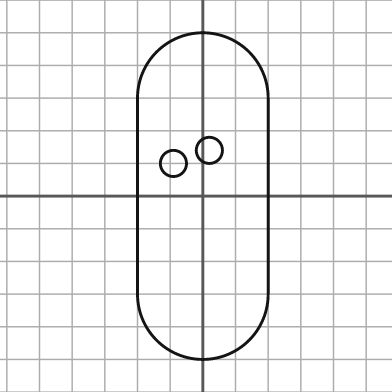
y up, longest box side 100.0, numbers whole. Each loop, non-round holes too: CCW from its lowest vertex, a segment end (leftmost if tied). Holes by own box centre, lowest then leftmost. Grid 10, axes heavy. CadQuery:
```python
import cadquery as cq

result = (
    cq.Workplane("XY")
    .moveTo(-20.0, -30.0)
    .threePointArc((0.0, -50.0), (20.0, -30.0))
    .lineTo(20.0, 30.0)
    .threePointArc((0.0, 50.0), (-20.0, 30.0))
    .close()
    .moveTo(-9.0, 10.0)
    .circle(4.0)
    .moveTo(2.0, 14.0)
    .circle(4.0)
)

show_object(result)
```